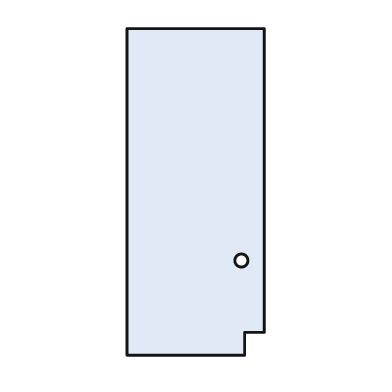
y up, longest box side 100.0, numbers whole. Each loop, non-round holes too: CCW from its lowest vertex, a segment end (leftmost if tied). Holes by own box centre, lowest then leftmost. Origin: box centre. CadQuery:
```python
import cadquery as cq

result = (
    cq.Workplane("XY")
    .moveTo(-21.0, -50.0)
    .lineTo(15.0, -50.0)
    .lineTo(15.0, -43.0)
    .lineTo(21.0, -43.0)
    .lineTo(21.0, 50.0)
    .lineTo(-21.0, 50.0)
    .close()
    .moveTo(14.0, -21.0)
    .circle(2.0)
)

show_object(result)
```